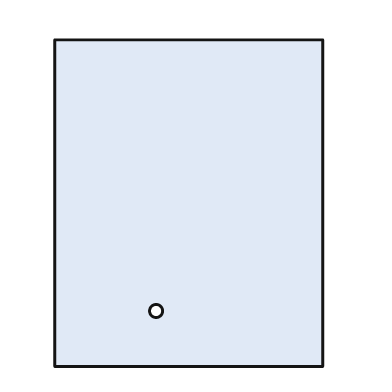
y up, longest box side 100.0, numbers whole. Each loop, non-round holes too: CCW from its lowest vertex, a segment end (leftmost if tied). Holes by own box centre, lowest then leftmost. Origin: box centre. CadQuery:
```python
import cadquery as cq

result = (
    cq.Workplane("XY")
    .moveTo(-41.0, -50.0)
    .lineTo(41.0, -50.0)
    .lineTo(41.0, 50.0)
    .lineTo(-41.0, 50.0)
    .close()
    .moveTo(-10.0, -33.0)
    .circle(2.0)
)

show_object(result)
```